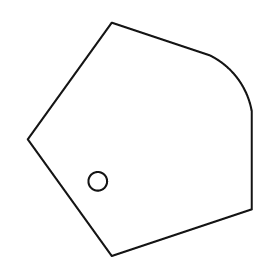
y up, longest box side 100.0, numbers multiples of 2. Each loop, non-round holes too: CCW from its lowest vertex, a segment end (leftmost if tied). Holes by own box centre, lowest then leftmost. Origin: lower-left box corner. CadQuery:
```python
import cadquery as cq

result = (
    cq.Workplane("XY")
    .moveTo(36.0, 0.0)
    .lineTo(96.0, 20.0)
    .lineTo(96.0, 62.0)
    .threePointArc((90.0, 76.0), (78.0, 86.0))
    .lineTo(36.0, 100.0)
    .lineTo(0.0, 50.0)
    .close()
    .moveTo(30.0, 32.0)
    .circle(4.0)
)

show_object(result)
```